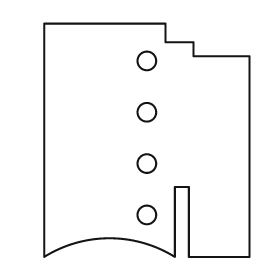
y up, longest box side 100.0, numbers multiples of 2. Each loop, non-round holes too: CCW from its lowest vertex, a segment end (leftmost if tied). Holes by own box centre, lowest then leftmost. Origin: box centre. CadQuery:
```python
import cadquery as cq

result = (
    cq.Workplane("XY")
    .moveTo(-44.0, -50.0)
    .threePointArc((-16.0, -42.0), (12.0, -50.0))
    .lineTo(12.0, -20.0)
    .lineTo(18.0, -20.0)
    .lineTo(18.0, -50.0)
    .lineTo(44.0, -50.0)
    .lineTo(44.0, 36.0)
    .lineTo(20.0, 36.0)
    .lineTo(20.0, 42.0)
    .lineTo(8.0, 42.0)
    .lineTo(8.0, 50.0)
    .lineTo(-44.0, 50.0)
    .close()
    .moveTo(0.0, -32.0)
    .circle(4.0)
    .moveTo(0.0, -10.0)
    .circle(4.0)
    .moveTo(0.0, 12.0)
    .circle(4.0)
    .moveTo(0.0, 34.0)
    .circle(4.0)
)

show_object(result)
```